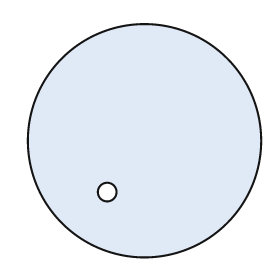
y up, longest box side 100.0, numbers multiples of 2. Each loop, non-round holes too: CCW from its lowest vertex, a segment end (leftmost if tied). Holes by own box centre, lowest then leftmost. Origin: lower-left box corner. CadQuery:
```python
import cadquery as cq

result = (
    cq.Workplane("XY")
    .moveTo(50.0, 50.0)
    .circle(50.0)
    .moveTo(34.0, 28.0)
    .circle(4.0)
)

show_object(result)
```